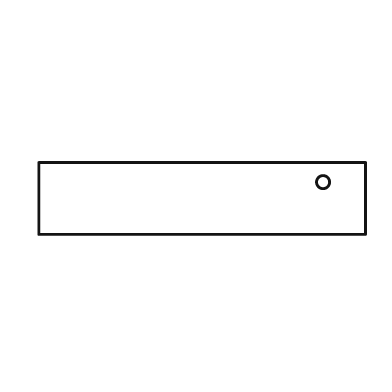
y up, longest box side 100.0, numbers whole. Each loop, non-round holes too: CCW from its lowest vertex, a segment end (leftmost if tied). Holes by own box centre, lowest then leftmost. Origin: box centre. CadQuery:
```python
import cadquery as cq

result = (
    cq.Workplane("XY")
    .moveTo(-50.0, -11.0)
    .lineTo(50.0, -11.0)
    .lineTo(50.0, 11.0)
    .lineTo(-50.0, 11.0)
    .close()
    .moveTo(37.0, 5.0)
    .circle(2.0)
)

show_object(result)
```